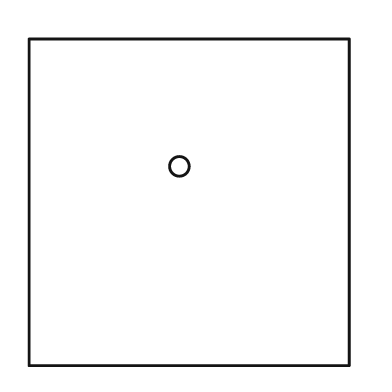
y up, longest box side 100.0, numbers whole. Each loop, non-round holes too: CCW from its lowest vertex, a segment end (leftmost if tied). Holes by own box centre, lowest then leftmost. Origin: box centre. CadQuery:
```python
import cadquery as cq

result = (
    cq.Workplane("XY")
    .moveTo(-49.0, -50.0)
    .lineTo(49.0, -50.0)
    .lineTo(49.0, 50.0)
    .lineTo(-49.0, 50.0)
    .close()
    .moveTo(-3.0, 11.0)
    .circle(3.0)
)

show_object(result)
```